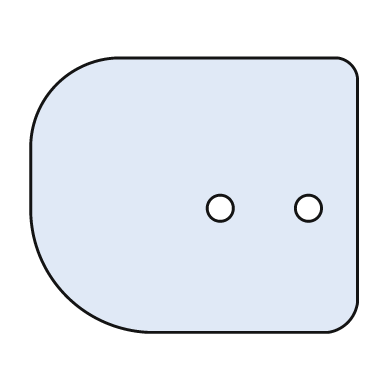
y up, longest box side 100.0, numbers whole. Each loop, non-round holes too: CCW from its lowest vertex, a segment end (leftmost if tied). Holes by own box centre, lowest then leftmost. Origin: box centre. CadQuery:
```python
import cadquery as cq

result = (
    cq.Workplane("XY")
    .moveTo(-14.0, -42.0)
    .lineTo(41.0, -42.0)
    .threePointArc((47.0, -39.0), (50.0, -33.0))
    .lineTo(50.0, 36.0)
    .threePointArc((48.0, 40.0), (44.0, 42.0))
    .lineTo(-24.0, 42.0)
    .threePointArc((-42.0, 34.0), (-50.0, 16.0))
    .lineTo(-50.0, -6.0)
    .threePointArc((-39.0, -31.0), (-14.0, -42.0))
    .close()
    .moveTo(8.0, -4.0)
    .circle(4.0)
    .moveTo(35.0, -4.0)
    .circle(4.0)
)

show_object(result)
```